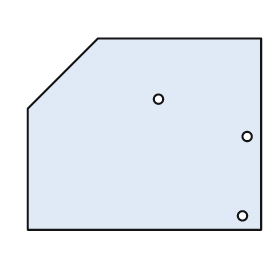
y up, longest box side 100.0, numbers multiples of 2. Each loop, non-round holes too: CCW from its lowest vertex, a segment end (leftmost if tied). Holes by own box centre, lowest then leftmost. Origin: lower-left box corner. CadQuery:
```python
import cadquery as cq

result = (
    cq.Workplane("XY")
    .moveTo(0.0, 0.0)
    .lineTo(100.0, 0.0)
    .lineTo(100.0, 82.0)
    .lineTo(30.0, 82.0)
    .lineTo(0.0, 52.0)
    .close()
    .moveTo(92.0, 6.0)
    .circle(2.0)
    .moveTo(94.0, 40.0)
    .circle(2.0)
    .moveTo(56.0, 56.0)
    .circle(2.0)
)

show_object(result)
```